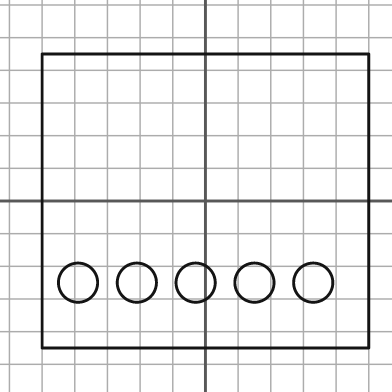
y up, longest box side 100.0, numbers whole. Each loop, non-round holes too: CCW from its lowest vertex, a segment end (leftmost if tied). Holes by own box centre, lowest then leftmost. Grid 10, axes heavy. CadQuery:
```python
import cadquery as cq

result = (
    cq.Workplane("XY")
    .moveTo(-50.0, -45.0)
    .lineTo(50.0, -45.0)
    .lineTo(50.0, 45.0)
    .lineTo(-50.0, 45.0)
    .close()
    .moveTo(-39.0, -25.0)
    .circle(6.0)
    .moveTo(-21.0, -25.0)
    .circle(6.0)
    .moveTo(-3.0, -25.0)
    .circle(6.0)
    .moveTo(15.0, -25.0)
    .circle(6.0)
    .moveTo(33.0, -25.0)
    .circle(6.0)
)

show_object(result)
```